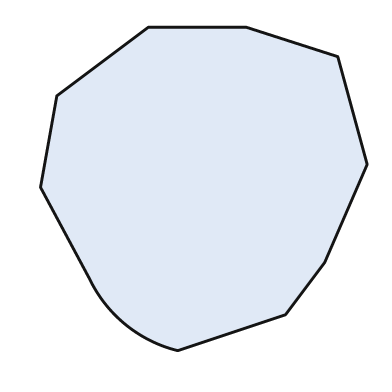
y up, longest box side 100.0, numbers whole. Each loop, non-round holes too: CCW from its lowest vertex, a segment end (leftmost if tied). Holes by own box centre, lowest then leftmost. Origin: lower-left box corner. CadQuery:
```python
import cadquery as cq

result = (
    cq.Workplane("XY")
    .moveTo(42.0, 0.0)
    .lineTo(75.0, 11.0)
    .lineTo(87.0, 27.0)
    .lineTo(100.0, 57.0)
    .lineTo(91.0, 90.0)
    .lineTo(63.0, 99.0)
    .lineTo(33.0, 99.0)
    .lineTo(5.0, 78.0)
    .lineTo(0.0, 50.0)
    .lineTo(15.0, 22.0)
    .threePointArc((26.0, 8.0), (42.0, 0.0))
    .close()
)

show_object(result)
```